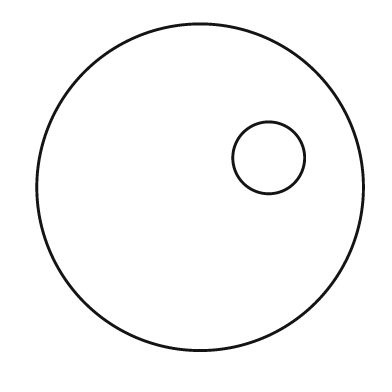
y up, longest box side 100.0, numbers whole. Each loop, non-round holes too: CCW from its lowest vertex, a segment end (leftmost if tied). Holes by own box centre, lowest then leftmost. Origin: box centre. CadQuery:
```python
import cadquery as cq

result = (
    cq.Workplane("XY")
    .moveTo(0.0, 0.0)
    .circle(50.0)
    .moveTo(21.0, 9.0)
    .circle(11.0)
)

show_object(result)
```